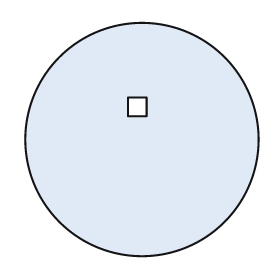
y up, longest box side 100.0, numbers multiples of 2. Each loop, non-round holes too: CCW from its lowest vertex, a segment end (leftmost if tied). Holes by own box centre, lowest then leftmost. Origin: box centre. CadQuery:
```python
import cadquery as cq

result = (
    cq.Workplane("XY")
    .moveTo(0.0, 0.0)
    .circle(50.0)
    .moveTo(-6.0, 10.0)
    .lineTo(2.0, 10.0)
    .lineTo(2.0, 18.0)
    .lineTo(-6.0, 18.0)
    .close()
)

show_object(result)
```